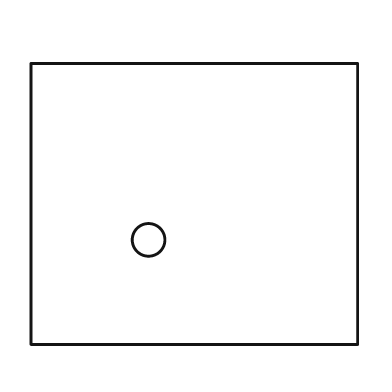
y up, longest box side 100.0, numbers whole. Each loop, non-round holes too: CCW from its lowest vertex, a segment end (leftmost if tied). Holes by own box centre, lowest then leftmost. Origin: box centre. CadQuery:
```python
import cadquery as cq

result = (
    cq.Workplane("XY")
    .moveTo(-50.0, -43.0)
    .lineTo(50.0, -43.0)
    .lineTo(50.0, 43.0)
    .lineTo(-50.0, 43.0)
    .close()
    .moveTo(-14.0, -11.0)
    .circle(5.0)
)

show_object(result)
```